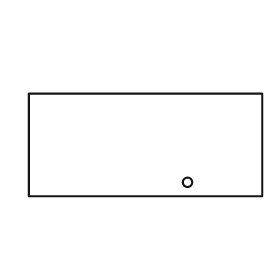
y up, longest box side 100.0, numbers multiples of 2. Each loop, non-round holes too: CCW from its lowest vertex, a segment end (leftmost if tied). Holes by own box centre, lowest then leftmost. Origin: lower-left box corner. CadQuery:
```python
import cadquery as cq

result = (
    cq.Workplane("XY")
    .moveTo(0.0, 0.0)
    .lineTo(100.0, 0.0)
    .lineTo(100.0, 44.0)
    .lineTo(0.0, 44.0)
    .close()
    .moveTo(68.0, 6.0)
    .circle(2.0)
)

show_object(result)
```